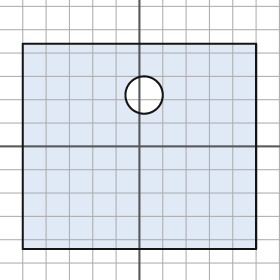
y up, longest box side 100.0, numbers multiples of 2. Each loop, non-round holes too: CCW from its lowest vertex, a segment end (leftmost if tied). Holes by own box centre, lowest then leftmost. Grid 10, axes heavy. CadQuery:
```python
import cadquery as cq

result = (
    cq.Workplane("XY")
    .moveTo(-50.0, -44.0)
    .lineTo(50.0, -44.0)
    .lineTo(50.0, 44.0)
    .lineTo(-50.0, 44.0)
    .close()
    .moveTo(2.0, 22.0)
    .circle(8.0)
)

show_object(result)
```